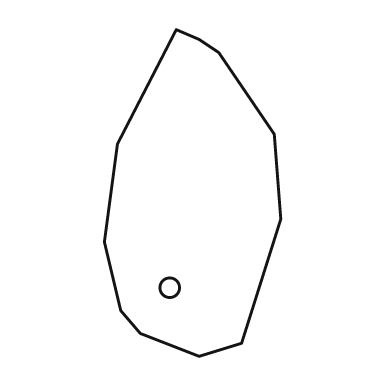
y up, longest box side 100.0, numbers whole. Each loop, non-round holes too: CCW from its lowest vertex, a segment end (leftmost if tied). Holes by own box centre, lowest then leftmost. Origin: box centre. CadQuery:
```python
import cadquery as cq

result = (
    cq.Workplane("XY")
    .moveTo(2.0, -50.0)
    .lineTo(15.0, -46.0)
    .lineTo(27.0, -8.0)
    .lineTo(25.0, 18.0)
    .lineTo(8.0, 43.0)
    .lineTo(2.0, 47.0)
    .lineTo(-5.0, 50.0)
    .lineTo(-23.0, 15.0)
    .lineTo(-27.0, -15.0)
    .lineTo(-22.0, -36.0)
    .lineTo(-16.0, -43.0)
    .close()
    .moveTo(-7.0, -29.0)
    .circle(3.0)
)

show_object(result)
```